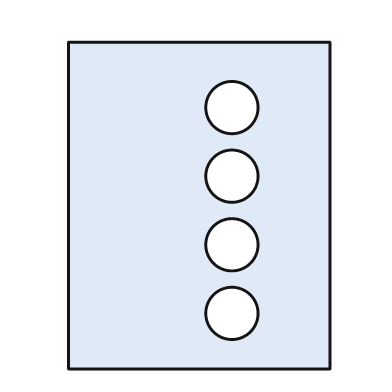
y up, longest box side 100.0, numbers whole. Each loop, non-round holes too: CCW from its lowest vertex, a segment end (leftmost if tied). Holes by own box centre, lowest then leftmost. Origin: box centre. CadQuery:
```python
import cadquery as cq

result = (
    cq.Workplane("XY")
    .moveTo(-40.0, -50.0)
    .lineTo(40.0, -50.0)
    .lineTo(40.0, 50.0)
    .lineTo(-40.0, 50.0)
    .close()
    .moveTo(10.0, -33.0)
    .circle(8.0)
    .moveTo(10.0, -12.0)
    .circle(8.0)
    .moveTo(10.0, 9.0)
    .circle(8.0)
    .moveTo(10.0, 30.0)
    .circle(8.0)
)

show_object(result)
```